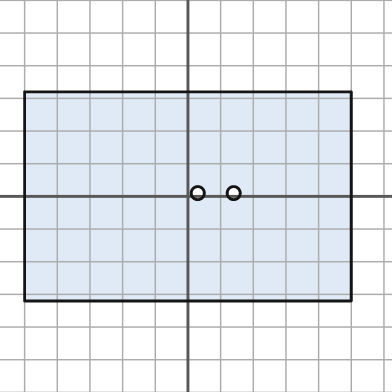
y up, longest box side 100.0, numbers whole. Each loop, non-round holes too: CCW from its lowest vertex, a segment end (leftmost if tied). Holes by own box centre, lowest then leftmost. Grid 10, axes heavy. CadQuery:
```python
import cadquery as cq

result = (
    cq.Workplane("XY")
    .moveTo(-50.0, -32.0)
    .lineTo(50.0, -32.0)
    .lineTo(50.0, 32.0)
    .lineTo(-50.0, 32.0)
    .close()
    .moveTo(3.0, 1.0)
    .circle(2.0)
    .moveTo(14.0, 1.0)
    .circle(2.0)
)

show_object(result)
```